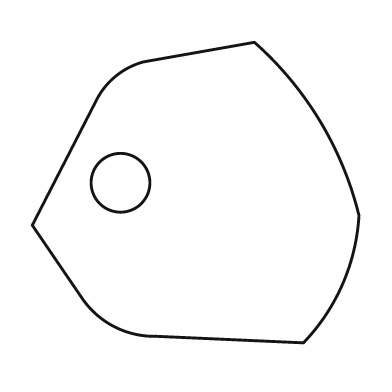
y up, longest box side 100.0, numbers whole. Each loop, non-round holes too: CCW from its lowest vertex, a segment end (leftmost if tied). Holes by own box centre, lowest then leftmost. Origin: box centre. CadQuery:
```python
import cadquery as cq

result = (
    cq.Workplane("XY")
    .moveTo(33.0, -46.0)
    .threePointArc((45.0, -28.0), (50.0, -7.0))
    .threePointArc((38.0, 22.0), (18.0, 46.0))
    .lineTo(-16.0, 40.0)
    .threePointArc((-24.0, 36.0), (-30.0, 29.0))
    .lineTo(-50.0, -10.0)
    .lineTo(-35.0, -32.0)
    .threePointArc((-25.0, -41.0), (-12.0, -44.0))
    .close()
    .moveTo(-23.0, 3.0)
    .circle(9.0)
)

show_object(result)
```